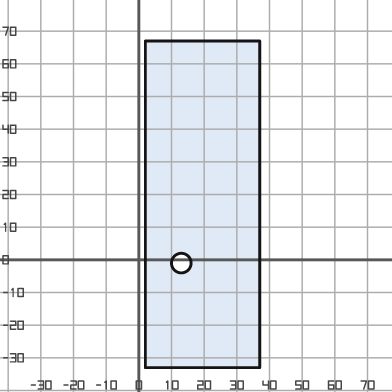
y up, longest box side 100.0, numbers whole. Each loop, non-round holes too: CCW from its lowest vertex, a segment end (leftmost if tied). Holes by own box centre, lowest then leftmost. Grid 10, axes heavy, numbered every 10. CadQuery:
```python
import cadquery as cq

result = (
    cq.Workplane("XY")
    .moveTo(2.0, -33.0)
    .lineTo(37.0, -33.0)
    .lineTo(37.0, 67.0)
    .lineTo(2.0, 67.0)
    .close()
    .moveTo(13.0, -1.0)
    .circle(3.0)
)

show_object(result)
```